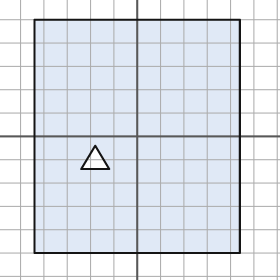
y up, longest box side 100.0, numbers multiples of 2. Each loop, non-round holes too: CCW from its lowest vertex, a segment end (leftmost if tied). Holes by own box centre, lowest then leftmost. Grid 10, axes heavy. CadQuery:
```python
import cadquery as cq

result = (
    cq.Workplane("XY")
    .moveTo(-44.0, -50.0)
    .lineTo(44.0, -50.0)
    .lineTo(44.0, 50.0)
    .lineTo(-44.0, 50.0)
    .close()
    .moveTo(-24.0, -14.0)
    .lineTo(-12.0, -14.0)
    .lineTo(-18.0, -4.0)
    .close()
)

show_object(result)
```